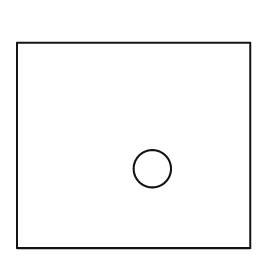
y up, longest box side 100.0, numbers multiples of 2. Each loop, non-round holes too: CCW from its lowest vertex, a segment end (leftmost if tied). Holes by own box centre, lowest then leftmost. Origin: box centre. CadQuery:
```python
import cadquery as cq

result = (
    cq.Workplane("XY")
    .moveTo(-50.0, -44.0)
    .lineTo(50.0, -44.0)
    .lineTo(50.0, 44.0)
    .lineTo(-50.0, 44.0)
    .close()
    .moveTo(8.0, -10.0)
    .circle(8.0)
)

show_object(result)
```